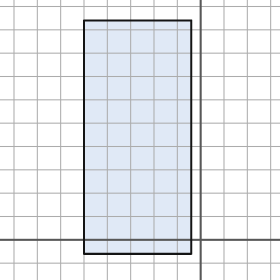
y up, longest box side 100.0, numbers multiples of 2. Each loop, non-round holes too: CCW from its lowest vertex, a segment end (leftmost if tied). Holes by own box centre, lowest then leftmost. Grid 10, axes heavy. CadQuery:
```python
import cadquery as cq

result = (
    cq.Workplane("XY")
    .moveTo(-50.0, -6.0)
    .lineTo(-4.0, -6.0)
    .lineTo(-4.0, 94.0)
    .lineTo(-50.0, 94.0)
    .close()
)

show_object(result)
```